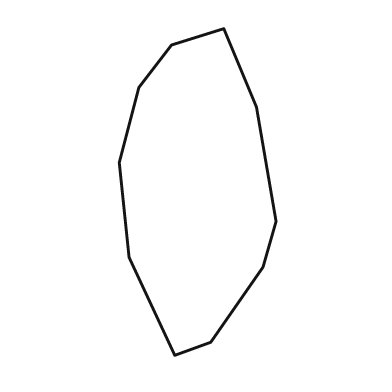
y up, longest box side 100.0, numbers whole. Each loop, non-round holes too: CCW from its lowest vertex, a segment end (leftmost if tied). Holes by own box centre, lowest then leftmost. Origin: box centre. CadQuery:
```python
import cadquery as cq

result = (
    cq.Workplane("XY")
    .moveTo(-7.0, -50.0)
    .lineTo(4.0, -46.0)
    .lineTo(20.0, -23.0)
    .lineTo(24.0, -9.0)
    .lineTo(18.0, 26.0)
    .lineTo(8.0, 50.0)
    .lineTo(-8.0, 45.0)
    .lineTo(-18.0, 32.0)
    .lineTo(-24.0, 9.0)
    .lineTo(-21.0, -20.0)
    .close()
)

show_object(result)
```